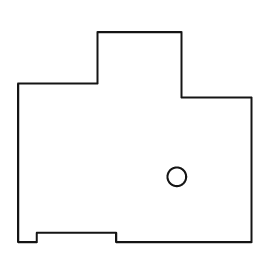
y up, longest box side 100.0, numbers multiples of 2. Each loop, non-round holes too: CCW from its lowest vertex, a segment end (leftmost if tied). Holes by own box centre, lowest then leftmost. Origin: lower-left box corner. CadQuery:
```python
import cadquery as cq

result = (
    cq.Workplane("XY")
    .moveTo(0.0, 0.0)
    .lineTo(8.0, 0.0)
    .lineTo(8.0, 4.0)
    .lineTo(42.0, 4.0)
    .lineTo(42.0, 0.0)
    .lineTo(100.0, 0.0)
    .lineTo(100.0, 62.0)
    .lineTo(70.0, 62.0)
    .lineTo(70.0, 90.0)
    .lineTo(34.0, 90.0)
    .lineTo(34.0, 68.0)
    .lineTo(0.0, 68.0)
    .close()
    .moveTo(68.0, 28.0)
    .circle(4.0)
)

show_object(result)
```